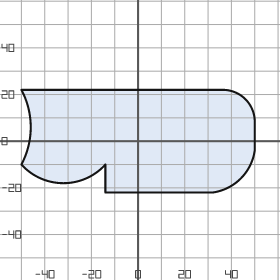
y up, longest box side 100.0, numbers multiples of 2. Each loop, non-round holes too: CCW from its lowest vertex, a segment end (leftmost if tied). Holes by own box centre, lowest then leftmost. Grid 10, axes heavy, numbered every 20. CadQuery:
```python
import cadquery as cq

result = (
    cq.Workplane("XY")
    .moveTo(-14.0, -22.0)
    .lineTo(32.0, -22.0)
    .threePointArc((44.0, -16.0), (50.0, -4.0))
    .lineTo(50.0, 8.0)
    .threePointArc((46.0, 18.0), (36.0, 22.0))
    .lineTo(-50.0, 22.0)
    .threePointArc((-46.0, 6.0), (-50.0, -10.0))
    .threePointArc((-32.0, -18.0), (-14.0, -10.0))
    .close()
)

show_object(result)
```